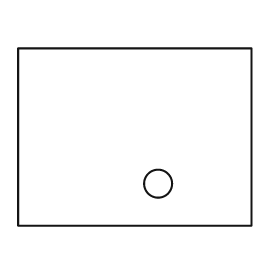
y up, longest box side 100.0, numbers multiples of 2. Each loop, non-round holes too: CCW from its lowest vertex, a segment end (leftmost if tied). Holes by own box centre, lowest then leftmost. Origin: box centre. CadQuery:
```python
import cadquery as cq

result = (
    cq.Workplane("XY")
    .moveTo(-50.0, -38.0)
    .lineTo(50.0, -38.0)
    .lineTo(50.0, 38.0)
    .lineTo(-50.0, 38.0)
    .close()
    .moveTo(10.0, -20.0)
    .circle(6.0)
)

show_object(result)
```